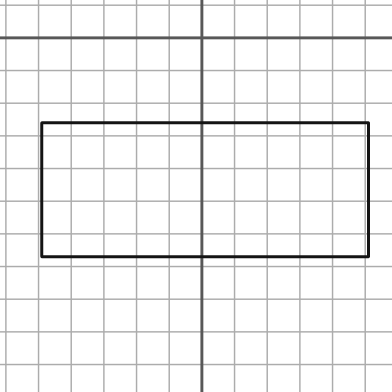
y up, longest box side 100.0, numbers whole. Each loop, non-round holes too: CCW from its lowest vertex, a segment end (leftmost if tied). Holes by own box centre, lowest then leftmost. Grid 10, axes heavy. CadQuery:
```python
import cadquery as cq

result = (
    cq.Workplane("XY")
    .moveTo(-49.0, -67.0)
    .lineTo(51.0, -67.0)
    .lineTo(51.0, -26.0)
    .lineTo(-49.0, -26.0)
    .close()
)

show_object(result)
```